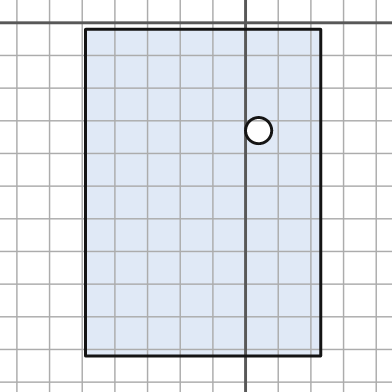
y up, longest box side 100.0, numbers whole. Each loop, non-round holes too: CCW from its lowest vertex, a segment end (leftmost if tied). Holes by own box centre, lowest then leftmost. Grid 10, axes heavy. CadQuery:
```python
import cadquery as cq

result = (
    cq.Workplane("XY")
    .moveTo(-49.0, -102.0)
    .lineTo(23.0, -102.0)
    .lineTo(23.0, -2.0)
    .lineTo(-49.0, -2.0)
    .close()
    .moveTo(4.0, -33.0)
    .circle(4.0)
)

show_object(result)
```